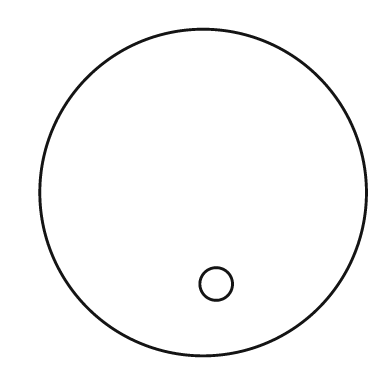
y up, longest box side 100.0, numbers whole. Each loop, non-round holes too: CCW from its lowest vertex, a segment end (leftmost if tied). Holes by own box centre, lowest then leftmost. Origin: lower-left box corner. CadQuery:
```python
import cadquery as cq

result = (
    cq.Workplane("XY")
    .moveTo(50.0, 50.0)
    .circle(50.0)
    .moveTo(54.0, 22.0)
    .circle(5.0)
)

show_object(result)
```